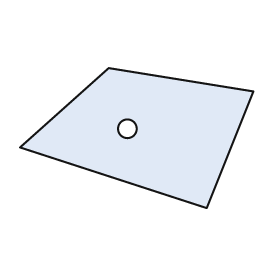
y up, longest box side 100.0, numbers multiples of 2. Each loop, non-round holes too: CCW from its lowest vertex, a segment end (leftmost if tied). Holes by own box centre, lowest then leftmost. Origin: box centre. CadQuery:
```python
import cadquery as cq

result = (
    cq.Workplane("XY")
    .moveTo(30.0, -30.0)
    .lineTo(50.0, 20.0)
    .lineTo(-12.0, 30.0)
    .lineTo(-50.0, -4.0)
    .close()
    .moveTo(-4.0, 4.0)
    .circle(4.0)
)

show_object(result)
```